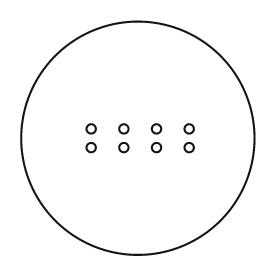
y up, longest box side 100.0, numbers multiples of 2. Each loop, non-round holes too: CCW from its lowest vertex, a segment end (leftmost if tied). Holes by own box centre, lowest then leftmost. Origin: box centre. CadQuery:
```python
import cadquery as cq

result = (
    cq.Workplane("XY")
    .moveTo(0.0, 0.0)
    .circle(50.0)
    .moveTo(-20.0, -4.0)
    .circle(2.0)
    .moveTo(-6.0, -4.0)
    .circle(2.0)
    .moveTo(8.0, -4.0)
    .circle(2.0)
    .moveTo(22.0, -4.0)
    .circle(2.0)
    .moveTo(-20.0, 4.0)
    .circle(2.0)
    .moveTo(-6.0, 4.0)
    .circle(2.0)
    .moveTo(8.0, 4.0)
    .circle(2.0)
    .moveTo(22.0, 4.0)
    .circle(2.0)
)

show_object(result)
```